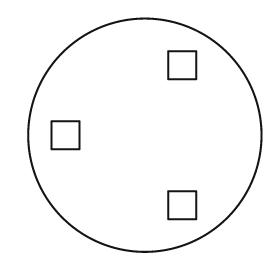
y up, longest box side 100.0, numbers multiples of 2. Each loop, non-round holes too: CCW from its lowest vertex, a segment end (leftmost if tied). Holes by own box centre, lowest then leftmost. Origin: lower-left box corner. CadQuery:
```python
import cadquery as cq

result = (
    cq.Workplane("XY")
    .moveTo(50.0, 50.0)
    .circle(50.0)
    .moveTo(60.0, 14.0)
    .lineTo(72.0, 14.0)
    .lineTo(72.0, 26.0)
    .lineTo(60.0, 26.0)
    .close()
    .moveTo(10.0, 44.0)
    .lineTo(22.0, 44.0)
    .lineTo(22.0, 56.0)
    .lineTo(10.0, 56.0)
    .close()
    .moveTo(60.0, 74.0)
    .lineTo(72.0, 74.0)
    .lineTo(72.0, 86.0)
    .lineTo(60.0, 86.0)
    .close()
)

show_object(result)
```